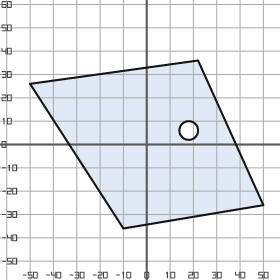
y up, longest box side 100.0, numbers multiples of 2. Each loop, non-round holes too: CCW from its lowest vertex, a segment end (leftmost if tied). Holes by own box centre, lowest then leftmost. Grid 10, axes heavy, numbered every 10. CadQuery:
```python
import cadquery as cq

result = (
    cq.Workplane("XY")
    .moveTo(-10.0, -36.0)
    .lineTo(50.0, -26.0)
    .lineTo(22.0, 36.0)
    .lineTo(-50.0, 26.0)
    .close()
    .moveTo(18.0, 6.0)
    .circle(4.0)
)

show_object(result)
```